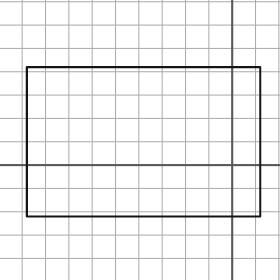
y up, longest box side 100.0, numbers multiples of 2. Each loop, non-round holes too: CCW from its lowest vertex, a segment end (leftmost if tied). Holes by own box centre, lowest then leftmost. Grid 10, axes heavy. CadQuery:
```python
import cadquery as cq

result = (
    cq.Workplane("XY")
    .moveTo(-88.0, -22.0)
    .lineTo(12.0, -22.0)
    .lineTo(12.0, 42.0)
    .lineTo(-88.0, 42.0)
    .close()
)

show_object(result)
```